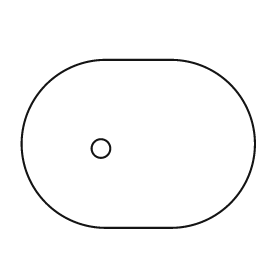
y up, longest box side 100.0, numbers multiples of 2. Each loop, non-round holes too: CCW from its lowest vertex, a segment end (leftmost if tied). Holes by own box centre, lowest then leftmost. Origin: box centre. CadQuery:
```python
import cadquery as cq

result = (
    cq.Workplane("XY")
    .moveTo(-14.0, -36.0)
    .lineTo(14.0, -36.0)
    .threePointArc((50.0, 0.0), (14.0, 36.0))
    .lineTo(-14.0, 36.0)
    .threePointArc((-50.0, 0.0), (-14.0, -36.0))
    .close()
    .moveTo(-16.0, -2.0)
    .circle(4.0)
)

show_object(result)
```